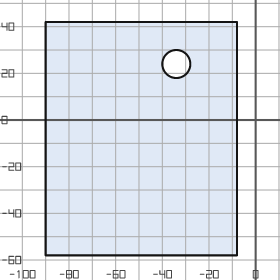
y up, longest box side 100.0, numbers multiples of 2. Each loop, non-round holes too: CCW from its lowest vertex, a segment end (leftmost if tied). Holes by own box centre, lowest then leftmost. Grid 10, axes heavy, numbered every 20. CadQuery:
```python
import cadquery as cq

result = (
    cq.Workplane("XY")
    .moveTo(-90.0, -58.0)
    .lineTo(-8.0, -58.0)
    .lineTo(-8.0, 42.0)
    .lineTo(-90.0, 42.0)
    .close()
    .moveTo(-34.0, 24.0)
    .circle(6.0)
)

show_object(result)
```